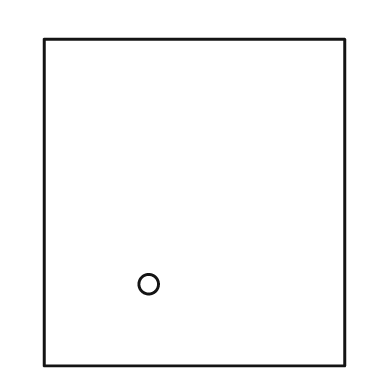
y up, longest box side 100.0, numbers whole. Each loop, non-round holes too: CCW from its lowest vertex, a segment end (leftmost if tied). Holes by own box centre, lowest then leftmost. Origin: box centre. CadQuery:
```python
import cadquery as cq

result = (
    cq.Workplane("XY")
    .moveTo(-46.0, -50.0)
    .lineTo(46.0, -50.0)
    .lineTo(46.0, 50.0)
    .lineTo(-46.0, 50.0)
    .close()
    .moveTo(-14.0, -25.0)
    .circle(3.0)
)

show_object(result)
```